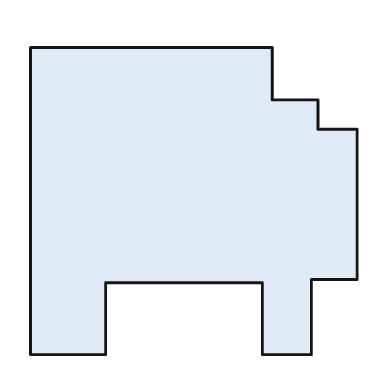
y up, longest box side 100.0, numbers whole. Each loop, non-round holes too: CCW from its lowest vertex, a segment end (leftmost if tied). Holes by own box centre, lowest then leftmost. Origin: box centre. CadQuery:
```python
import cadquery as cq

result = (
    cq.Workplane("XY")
    .moveTo(-50.0, -47.0)
    .lineTo(-27.0, -47.0)
    .lineTo(-27.0, -25.0)
    .lineTo(21.0, -25.0)
    .lineTo(21.0, -47.0)
    .lineTo(36.0, -47.0)
    .lineTo(36.0, -24.0)
    .lineTo(50.0, -24.0)
    .lineTo(50.0, 22.0)
    .lineTo(38.0, 22.0)
    .lineTo(38.0, 31.0)
    .lineTo(24.0, 31.0)
    .lineTo(24.0, 47.0)
    .lineTo(-50.0, 47.0)
    .close()
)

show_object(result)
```